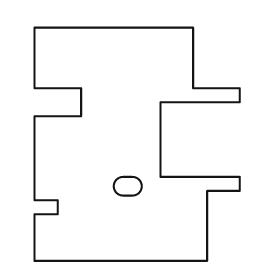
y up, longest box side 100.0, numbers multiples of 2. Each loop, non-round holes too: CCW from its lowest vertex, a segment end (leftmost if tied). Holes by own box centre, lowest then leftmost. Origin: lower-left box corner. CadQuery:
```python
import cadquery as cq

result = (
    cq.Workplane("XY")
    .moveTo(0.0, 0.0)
    .lineTo(74.0, 0.0)
    .lineTo(74.0, 30.0)
    .lineTo(88.0, 30.0)
    .lineTo(88.0, 36.0)
    .lineTo(54.0, 36.0)
    .lineTo(54.0, 68.0)
    .lineTo(88.0, 68.0)
    .lineTo(88.0, 74.0)
    .lineTo(68.0, 74.0)
    .lineTo(68.0, 100.0)
    .lineTo(0.0, 100.0)
    .lineTo(0.0, 74.0)
    .lineTo(20.0, 74.0)
    .lineTo(20.0, 62.0)
    .lineTo(0.0, 62.0)
    .lineTo(0.0, 26.0)
    .lineTo(10.0, 26.0)
    .lineTo(10.0, 20.0)
    .lineTo(0.0, 20.0)
    .close()
    .moveTo(38.0, 28.0)
    .lineTo(42.0, 28.0)
    .threePointArc((46.0, 32.0), (42.0, 36.0))
    .lineTo(38.0, 36.0)
    .threePointArc((34.0, 32.0), (38.0, 28.0))
    .close()
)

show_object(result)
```